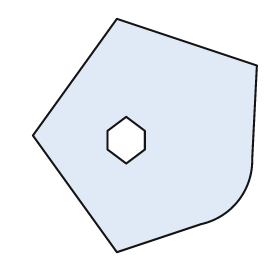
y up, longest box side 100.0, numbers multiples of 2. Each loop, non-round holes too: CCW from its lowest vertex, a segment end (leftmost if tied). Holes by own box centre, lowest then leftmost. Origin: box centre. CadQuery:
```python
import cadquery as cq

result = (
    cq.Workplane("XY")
    .moveTo(-12.0, -50.0)
    .lineTo(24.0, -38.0)
    .threePointArc((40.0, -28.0), (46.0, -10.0))
    .lineTo(48.0, 30.0)
    .lineTo(-12.0, 50.0)
    .lineTo(-48.0, 0.0)
    .close()
    .moveTo(-8.0, -12.0)
    .lineTo(0.0, -6.0)
    .lineTo(0.0, 2.0)
    .lineTo(-8.0, 8.0)
    .lineTo(-16.0, 2.0)
    .lineTo(-16.0, -6.0)
    .close()
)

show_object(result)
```